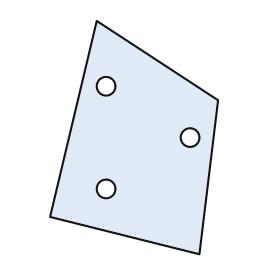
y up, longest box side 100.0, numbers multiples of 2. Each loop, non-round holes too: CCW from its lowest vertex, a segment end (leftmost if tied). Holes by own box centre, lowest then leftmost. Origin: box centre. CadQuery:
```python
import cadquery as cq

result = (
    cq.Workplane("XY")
    .moveTo(28.0, -50.0)
    .lineTo(36.0, 16.0)
    .lineTo(-16.0, 50.0)
    .lineTo(-36.0, -34.0)
    .close()
    .moveTo(-12.0, -22.0)
    .circle(4.0)
    .moveTo(24.0, 0.0)
    .circle(4.0)
    .moveTo(-12.0, 22.0)
    .circle(4.0)
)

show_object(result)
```